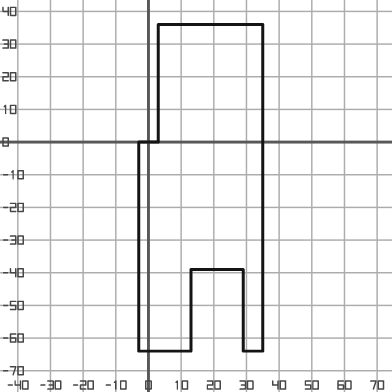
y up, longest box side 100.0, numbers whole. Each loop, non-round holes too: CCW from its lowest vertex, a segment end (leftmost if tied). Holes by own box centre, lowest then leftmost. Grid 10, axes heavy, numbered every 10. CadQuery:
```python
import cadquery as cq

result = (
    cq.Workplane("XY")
    .moveTo(-3.0, -64.0)
    .lineTo(13.0, -64.0)
    .lineTo(13.0, -39.0)
    .lineTo(29.0, -39.0)
    .lineTo(29.0, -64.0)
    .lineTo(35.0, -64.0)
    .lineTo(35.0, 36.0)
    .lineTo(3.0, 36.0)
    .lineTo(3.0, 0.0)
    .lineTo(-3.0, 0.0)
    .close()
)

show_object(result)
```